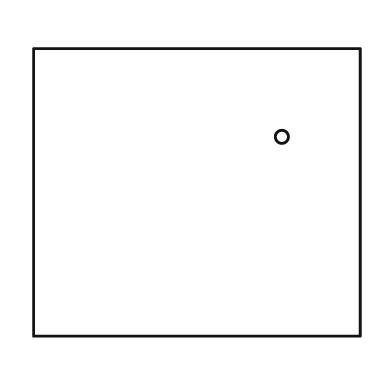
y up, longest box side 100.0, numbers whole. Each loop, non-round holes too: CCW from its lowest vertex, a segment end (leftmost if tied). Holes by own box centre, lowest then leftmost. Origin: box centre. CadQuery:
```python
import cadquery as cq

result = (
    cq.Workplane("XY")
    .moveTo(-50.0, -44.0)
    .lineTo(50.0, -44.0)
    .lineTo(50.0, 44.0)
    .lineTo(-50.0, 44.0)
    .close()
    .moveTo(26.0, 17.0)
    .circle(2.0)
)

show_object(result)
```